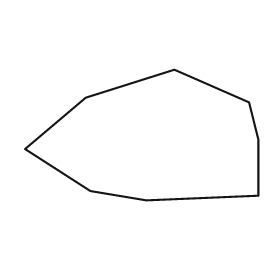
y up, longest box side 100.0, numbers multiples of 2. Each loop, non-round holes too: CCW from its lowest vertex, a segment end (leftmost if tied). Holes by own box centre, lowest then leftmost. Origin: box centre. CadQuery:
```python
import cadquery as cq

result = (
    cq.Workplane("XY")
    .moveTo(2.0, -28.0)
    .lineTo(50.0, -26.0)
    .lineTo(50.0, -2.0)
    .lineTo(46.0, 14.0)
    .lineTo(14.0, 28.0)
    .lineTo(-24.0, 16.0)
    .lineTo(-50.0, -6.0)
    .lineTo(-22.0, -24.0)
    .close()
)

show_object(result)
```